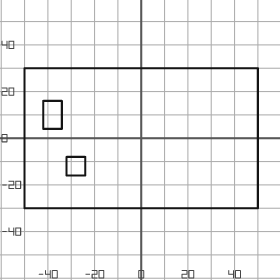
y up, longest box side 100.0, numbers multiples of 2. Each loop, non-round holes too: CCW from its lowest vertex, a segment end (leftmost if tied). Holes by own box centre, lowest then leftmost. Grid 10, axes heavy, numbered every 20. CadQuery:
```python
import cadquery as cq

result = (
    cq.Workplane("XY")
    .moveTo(-50.0, -30.0)
    .lineTo(50.0, -30.0)
    .lineTo(50.0, 30.0)
    .lineTo(-50.0, 30.0)
    .close()
    .moveTo(-32.0, -16.0)
    .lineTo(-24.0, -16.0)
    .lineTo(-24.0, -8.0)
    .lineTo(-32.0, -8.0)
    .close()
    .moveTo(-42.0, 4.0)
    .lineTo(-34.0, 4.0)
    .lineTo(-34.0, 16.0)
    .lineTo(-42.0, 16.0)
    .close()
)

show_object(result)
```